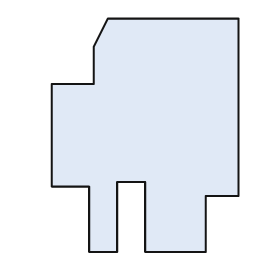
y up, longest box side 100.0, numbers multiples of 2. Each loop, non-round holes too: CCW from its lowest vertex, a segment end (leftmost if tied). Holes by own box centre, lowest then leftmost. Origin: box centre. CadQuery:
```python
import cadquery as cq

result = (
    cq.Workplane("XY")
    .moveTo(-24.0, -50.0)
    .lineTo(-12.0, -50.0)
    .lineTo(-12.0, -20.0)
    .lineTo(0.0, -20.0)
    .lineTo(0.0, -50.0)
    .lineTo(26.0, -50.0)
    .lineTo(26.0, -26.0)
    .lineTo(40.0, -26.0)
    .lineTo(40.0, 50.0)
    .lineTo(-16.0, 50.0)
    .lineTo(-22.0, 38.0)
    .lineTo(-22.0, 22.0)
    .lineTo(-40.0, 22.0)
    .lineTo(-40.0, -22.0)
    .lineTo(-24.0, -22.0)
    .close()
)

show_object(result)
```